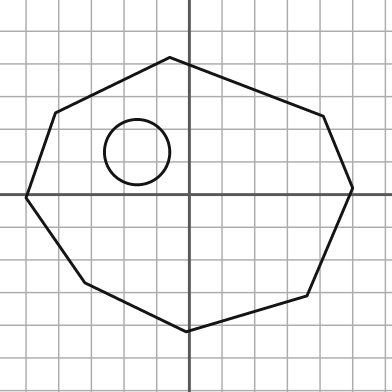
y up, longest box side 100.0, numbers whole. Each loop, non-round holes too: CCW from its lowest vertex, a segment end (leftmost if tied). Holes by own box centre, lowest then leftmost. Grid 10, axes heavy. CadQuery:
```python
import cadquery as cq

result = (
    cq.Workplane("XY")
    .moveTo(-1.0, -42.0)
    .lineTo(36.0, -31.0)
    .lineTo(50.0, 2.0)
    .lineTo(41.0, 24.0)
    .lineTo(-6.0, 42.0)
    .lineTo(-41.0, 25.0)
    .lineTo(-50.0, -1.0)
    .lineTo(-32.0, -27.0)
    .close()
    .moveTo(-16.0, 13.0)
    .circle(10.0)
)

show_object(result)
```